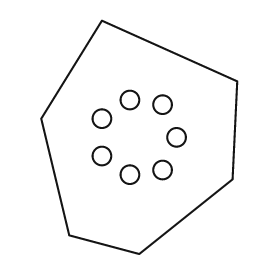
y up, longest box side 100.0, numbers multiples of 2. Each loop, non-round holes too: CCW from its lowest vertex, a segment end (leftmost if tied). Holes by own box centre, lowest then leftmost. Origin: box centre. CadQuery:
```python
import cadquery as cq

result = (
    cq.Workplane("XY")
    .moveTo(0.0, -50.0)
    .lineTo(40.0, -18.0)
    .lineTo(42.0, 24.0)
    .lineTo(-16.0, 50.0)
    .lineTo(-42.0, 8.0)
    .lineTo(-30.0, -42.0)
    .close()
    .moveTo(-4.0, -16.0)
    .circle(4.0)
    .moveTo(10.0, -14.0)
    .circle(4.0)
    .moveTo(-16.0, -8.0)
    .circle(4.0)
    .moveTo(16.0, 0.0)
    .circle(4.0)
    .moveTo(-16.0, 8.0)
    .circle(4.0)
    .moveTo(10.0, 14.0)
    .circle(4.0)
    .moveTo(-4.0, 16.0)
    .circle(4.0)
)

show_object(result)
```